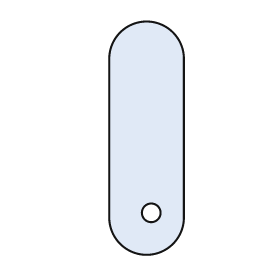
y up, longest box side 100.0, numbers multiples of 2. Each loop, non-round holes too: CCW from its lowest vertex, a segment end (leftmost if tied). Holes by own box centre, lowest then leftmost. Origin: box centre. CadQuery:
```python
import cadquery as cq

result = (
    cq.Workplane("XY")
    .moveTo(-16.0, -34.0)
    .threePointArc((0.0, -50.0), (16.0, -34.0))
    .lineTo(16.0, 34.0)
    .threePointArc((0.0, 50.0), (-16.0, 34.0))
    .close()
    .moveTo(2.0, -32.0)
    .circle(4.0)
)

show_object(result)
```